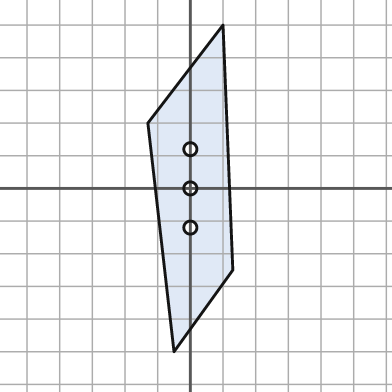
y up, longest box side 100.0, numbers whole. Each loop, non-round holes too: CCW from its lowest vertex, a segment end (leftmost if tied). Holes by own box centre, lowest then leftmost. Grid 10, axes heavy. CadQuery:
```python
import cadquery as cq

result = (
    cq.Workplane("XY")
    .moveTo(-5.0, -50.0)
    .lineTo(13.0, -25.0)
    .lineTo(10.0, 50.0)
    .lineTo(-13.0, 20.0)
    .close()
    .moveTo(0.0, -12.0)
    .circle(2.0)
    .moveTo(0.0, 0.0)
    .circle(2.0)
    .moveTo(0.0, 12.0)
    .circle(2.0)
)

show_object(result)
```